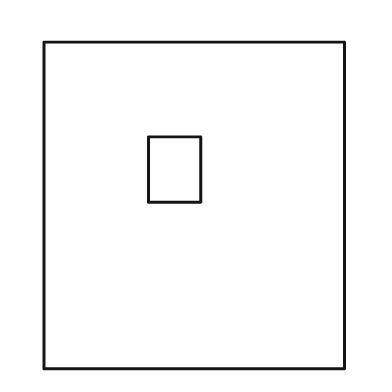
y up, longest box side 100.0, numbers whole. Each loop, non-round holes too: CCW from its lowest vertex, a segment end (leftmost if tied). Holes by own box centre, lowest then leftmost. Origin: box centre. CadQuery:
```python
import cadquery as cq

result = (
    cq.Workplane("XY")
    .moveTo(-46.0, -50.0)
    .lineTo(46.0, -50.0)
    .lineTo(46.0, 50.0)
    .lineTo(-46.0, 50.0)
    .close()
    .moveTo(-14.0, 1.0)
    .lineTo(2.0, 1.0)
    .lineTo(2.0, 21.0)
    .lineTo(-14.0, 21.0)
    .close()
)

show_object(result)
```